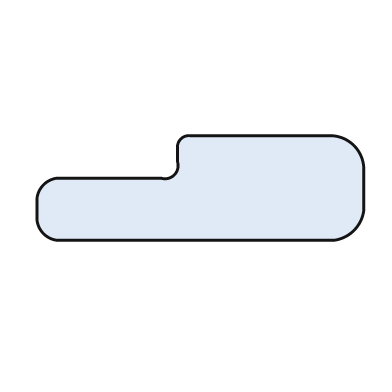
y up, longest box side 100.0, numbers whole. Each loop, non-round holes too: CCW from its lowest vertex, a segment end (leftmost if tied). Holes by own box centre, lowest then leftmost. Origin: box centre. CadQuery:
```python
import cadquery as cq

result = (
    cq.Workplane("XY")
    .moveTo(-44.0, -16.0)
    .lineTo(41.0, -16.0)
    .threePointArc((47.0, -13.0), (50.0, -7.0))
    .lineTo(50.0, 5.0)
    .threePointArc((47.0, 13.0), (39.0, 16.0))
    .lineTo(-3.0, 16.0)
    .threePointArc((-6.0, 15.0), (-7.0, 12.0))
    .lineTo(-7.0, 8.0)
    .threePointArc((-8.0, 4.0), (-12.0, 3.0))
    .lineTo(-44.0, 3.0)
    .threePointArc((-48.0, 1.0), (-50.0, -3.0))
    .lineTo(-50.0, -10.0)
    .threePointArc((-48.0, -14.0), (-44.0, -16.0))
    .close()
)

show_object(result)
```